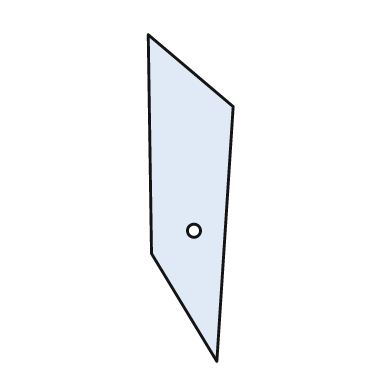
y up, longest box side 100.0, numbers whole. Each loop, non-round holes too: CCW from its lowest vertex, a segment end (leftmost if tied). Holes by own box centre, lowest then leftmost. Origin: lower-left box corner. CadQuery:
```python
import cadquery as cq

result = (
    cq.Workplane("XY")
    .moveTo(21.0, 0.0)
    .lineTo(26.0, 78.0)
    .lineTo(0.0, 100.0)
    .lineTo(1.0, 33.0)
    .close()
    .moveTo(14.0, 40.0)
    .circle(2.0)
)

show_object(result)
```